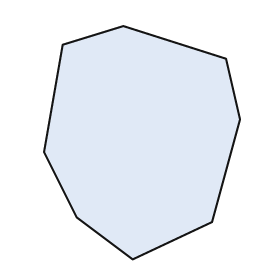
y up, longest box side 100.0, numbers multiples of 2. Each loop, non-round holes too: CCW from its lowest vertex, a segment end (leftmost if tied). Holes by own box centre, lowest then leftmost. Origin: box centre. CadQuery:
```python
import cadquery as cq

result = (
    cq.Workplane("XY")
    .moveTo(-4.0, -50.0)
    .lineTo(30.0, -34.0)
    .lineTo(42.0, 10.0)
    .lineTo(36.0, 36.0)
    .lineTo(-8.0, 50.0)
    .lineTo(-34.0, 42.0)
    .lineTo(-42.0, -4.0)
    .lineTo(-28.0, -32.0)
    .close()
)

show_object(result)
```